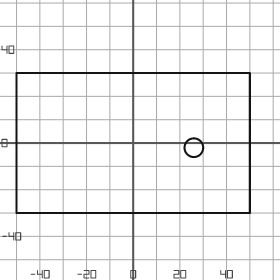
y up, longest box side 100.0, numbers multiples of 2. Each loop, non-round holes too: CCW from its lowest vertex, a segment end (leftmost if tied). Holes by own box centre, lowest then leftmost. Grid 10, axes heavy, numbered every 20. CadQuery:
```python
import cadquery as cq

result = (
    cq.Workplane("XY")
    .moveTo(-50.0, -30.0)
    .lineTo(50.0, -30.0)
    .lineTo(50.0, 30.0)
    .lineTo(-50.0, 30.0)
    .close()
    .moveTo(26.0, -2.0)
    .circle(4.0)
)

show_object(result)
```